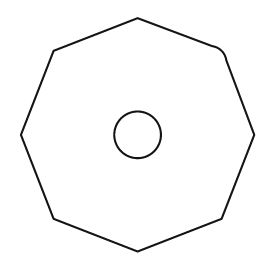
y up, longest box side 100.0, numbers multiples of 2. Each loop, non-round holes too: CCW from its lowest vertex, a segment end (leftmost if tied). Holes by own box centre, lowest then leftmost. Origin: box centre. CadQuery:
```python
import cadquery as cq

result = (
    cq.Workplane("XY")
    .moveTo(0.0, -50.0)
    .lineTo(36.0, -36.0)
    .lineTo(50.0, 0.0)
    .lineTo(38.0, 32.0)
    .threePointArc((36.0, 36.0), (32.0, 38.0))
    .lineTo(0.0, 50.0)
    .lineTo(-36.0, 36.0)
    .lineTo(-50.0, 0.0)
    .lineTo(-36.0, -36.0)
    .close()
    .moveTo(0.0, 0.0)
    .circle(10.0)
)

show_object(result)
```